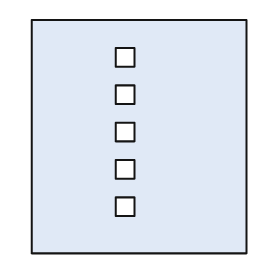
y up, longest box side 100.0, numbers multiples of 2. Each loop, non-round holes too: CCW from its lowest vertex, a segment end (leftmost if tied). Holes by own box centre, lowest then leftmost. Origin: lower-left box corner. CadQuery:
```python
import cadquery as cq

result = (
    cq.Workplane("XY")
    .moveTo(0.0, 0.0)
    .lineTo(92.0, 0.0)
    .lineTo(92.0, 100.0)
    .lineTo(0.0, 100.0)
    .close()
    .moveTo(36.0, 16.0)
    .lineTo(44.0, 16.0)
    .lineTo(44.0, 24.0)
    .lineTo(36.0, 24.0)
    .close()
    .moveTo(36.0, 32.0)
    .lineTo(44.0, 32.0)
    .lineTo(44.0, 40.0)
    .lineTo(36.0, 40.0)
    .close()
    .moveTo(36.0, 48.0)
    .lineTo(44.0, 48.0)
    .lineTo(44.0, 56.0)
    .lineTo(36.0, 56.0)
    .close()
    .moveTo(36.0, 64.0)
    .lineTo(44.0, 64.0)
    .lineTo(44.0, 72.0)
    .lineTo(36.0, 72.0)
    .close()
    .moveTo(36.0, 80.0)
    .lineTo(44.0, 80.0)
    .lineTo(44.0, 88.0)
    .lineTo(36.0, 88.0)
    .close()
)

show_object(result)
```